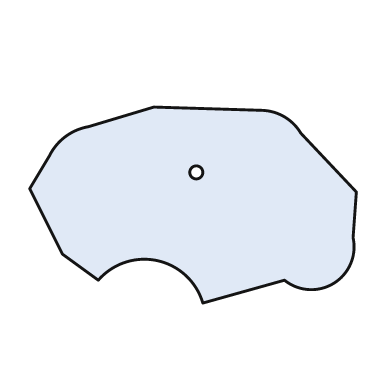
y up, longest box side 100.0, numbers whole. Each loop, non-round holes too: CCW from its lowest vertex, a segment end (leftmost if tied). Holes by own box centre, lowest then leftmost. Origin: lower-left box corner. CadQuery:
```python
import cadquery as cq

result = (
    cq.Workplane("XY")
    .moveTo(53.0, 0.0)
    .lineTo(78.0, 7.0)
    .threePointArc((93.0, 6.0), (99.0, 20.0))
    .lineTo(100.0, 34.0)
    .lineTo(83.0, 52.0)
    .threePointArc((78.0, 57.0), (71.0, 59.0))
    .lineTo(38.0, 60.0)
    .lineTo(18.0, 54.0)
    .threePointArc((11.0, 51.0), (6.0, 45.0))
    .lineTo(0.0, 35.0)
    .lineTo(10.0, 15.0)
    .lineTo(21.0, 7.0)
    .threePointArc((39.0, 13.0), (53.0, 0.0))
    .close()
    .moveTo(51.0, 40.0)
    .circle(2.0)
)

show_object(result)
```